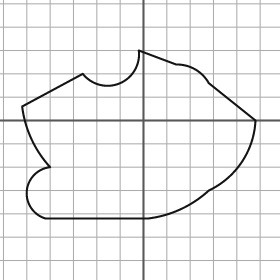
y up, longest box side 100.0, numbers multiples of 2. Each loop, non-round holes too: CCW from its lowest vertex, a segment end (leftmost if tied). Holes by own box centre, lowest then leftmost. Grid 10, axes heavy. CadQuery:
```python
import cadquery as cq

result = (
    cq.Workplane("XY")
    .moveTo(-42.0, -42.0)
    .lineTo(2.0, -42.0)
    .threePointArc((16.0, -38.0), (28.0, -30.0))
    .threePointArc((42.0, -18.0), (48.0, 0.0))
    .lineTo(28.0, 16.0)
    .threePointArc((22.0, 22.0), (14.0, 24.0))
    .lineTo(-2.0, 30.0)
    .threePointArc((-10.0, 16.0), (-26.0, 20.0))
    .lineTo(-52.0, 6.0)
    .threePointArc((-48.0, -8.0), (-40.0, -20.0))
    .threePointArc((-50.0, -30.0), (-42.0, -42.0))
    .close()
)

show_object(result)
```